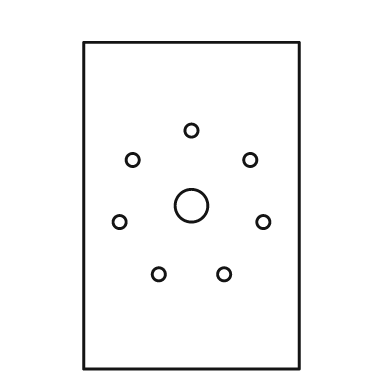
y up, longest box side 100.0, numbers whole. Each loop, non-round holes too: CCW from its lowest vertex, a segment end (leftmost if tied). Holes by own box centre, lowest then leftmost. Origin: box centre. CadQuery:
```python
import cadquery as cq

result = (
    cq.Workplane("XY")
    .moveTo(-33.0, -50.0)
    .lineTo(33.0, -50.0)
    .lineTo(33.0, 50.0)
    .lineTo(-33.0, 50.0)
    .close()
    .moveTo(-10.0, -21.0)
    .circle(2.0)
    .moveTo(10.0, -21.0)
    .circle(2.0)
    .moveTo(-22.0, -5.0)
    .circle(2.0)
    .moveTo(22.0, -5.0)
    .circle(2.0)
    .moveTo(0.0, 0.0)
    .circle(5.0)
    .moveTo(-18.0, 14.0)
    .circle(2.0)
    .moveTo(18.0, 14.0)
    .circle(2.0)
    .moveTo(0.0, 23.0)
    .circle(2.0)
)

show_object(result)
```